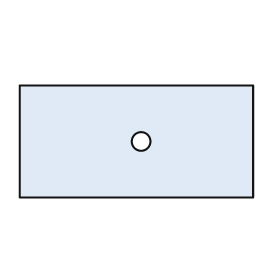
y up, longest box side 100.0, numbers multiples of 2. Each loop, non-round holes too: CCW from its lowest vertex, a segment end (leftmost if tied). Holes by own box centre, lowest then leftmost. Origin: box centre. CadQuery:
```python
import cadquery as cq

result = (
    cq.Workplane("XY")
    .moveTo(-50.0, -24.0)
    .lineTo(50.0, -24.0)
    .lineTo(50.0, 24.0)
    .lineTo(-50.0, 24.0)
    .close()
    .moveTo(2.0, 0.0)
    .circle(4.0)
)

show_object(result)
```